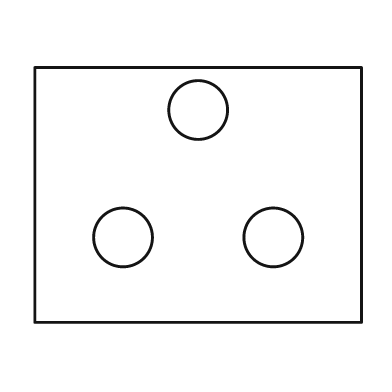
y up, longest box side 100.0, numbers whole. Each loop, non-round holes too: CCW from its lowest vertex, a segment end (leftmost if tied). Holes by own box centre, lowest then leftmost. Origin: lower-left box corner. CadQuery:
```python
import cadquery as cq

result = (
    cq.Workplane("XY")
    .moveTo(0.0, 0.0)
    .lineTo(100.0, 0.0)
    .lineTo(100.0, 78.0)
    .lineTo(0.0, 78.0)
    .close()
    .moveTo(27.0, 26.0)
    .circle(9.0)
    .moveTo(73.0, 26.0)
    .circle(9.0)
    .moveTo(50.0, 65.0)
    .circle(9.0)
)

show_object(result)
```